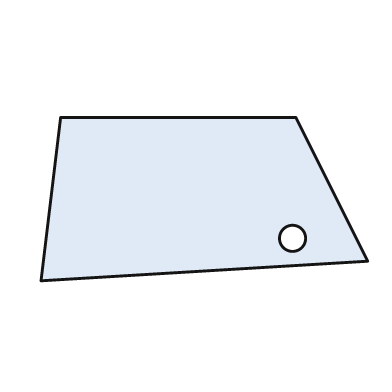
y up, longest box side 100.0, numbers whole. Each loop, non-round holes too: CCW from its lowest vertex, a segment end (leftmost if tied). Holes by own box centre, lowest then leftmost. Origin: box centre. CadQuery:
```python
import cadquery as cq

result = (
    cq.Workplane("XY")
    .moveTo(-50.0, -25.0)
    .lineTo(50.0, -19.0)
    .lineTo(28.0, 25.0)
    .lineTo(-44.0, 25.0)
    .close()
    .moveTo(27.0, -12.0)
    .circle(4.0)
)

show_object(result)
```